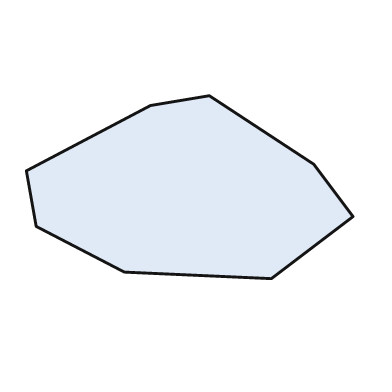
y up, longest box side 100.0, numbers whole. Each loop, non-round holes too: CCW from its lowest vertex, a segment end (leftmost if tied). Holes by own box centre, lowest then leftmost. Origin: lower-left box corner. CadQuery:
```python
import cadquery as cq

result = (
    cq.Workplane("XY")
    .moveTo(75.0, 0.0)
    .lineTo(100.0, 19.0)
    .lineTo(88.0, 35.0)
    .lineTo(56.0, 56.0)
    .lineTo(38.0, 53.0)
    .lineTo(0.0, 33.0)
    .lineTo(3.0, 16.0)
    .lineTo(30.0, 2.0)
    .close()
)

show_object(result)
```